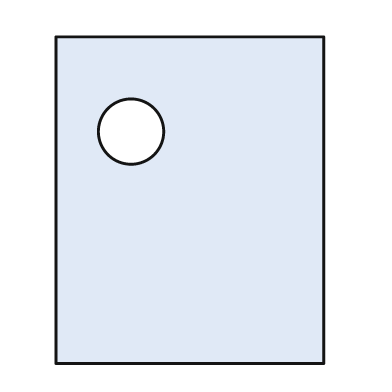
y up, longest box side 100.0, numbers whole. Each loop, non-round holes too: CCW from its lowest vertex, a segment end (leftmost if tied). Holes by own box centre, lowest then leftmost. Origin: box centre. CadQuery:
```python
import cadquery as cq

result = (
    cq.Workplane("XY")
    .moveTo(-41.0, -50.0)
    .lineTo(41.0, -50.0)
    .lineTo(41.0, 50.0)
    .lineTo(-41.0, 50.0)
    .close()
    .moveTo(-18.0, 21.0)
    .circle(10.0)
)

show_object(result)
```